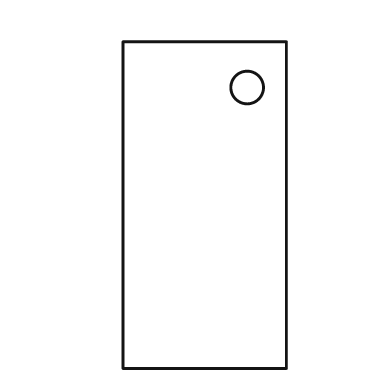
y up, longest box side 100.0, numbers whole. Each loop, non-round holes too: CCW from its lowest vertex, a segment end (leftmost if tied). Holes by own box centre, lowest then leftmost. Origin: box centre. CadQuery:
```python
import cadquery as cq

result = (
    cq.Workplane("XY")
    .moveTo(-25.0, -50.0)
    .lineTo(25.0, -50.0)
    .lineTo(25.0, 50.0)
    .lineTo(-25.0, 50.0)
    .close()
    .moveTo(13.0, 36.0)
    .circle(5.0)
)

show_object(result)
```